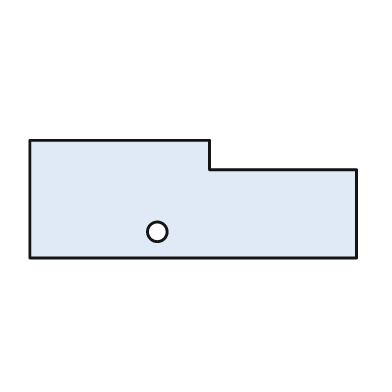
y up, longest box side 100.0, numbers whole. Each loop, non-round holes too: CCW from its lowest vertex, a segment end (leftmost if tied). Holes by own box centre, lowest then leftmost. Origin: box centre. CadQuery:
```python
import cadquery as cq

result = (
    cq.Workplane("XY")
    .moveTo(-50.0, -18.0)
    .lineTo(50.0, -18.0)
    .lineTo(50.0, 9.0)
    .lineTo(5.0, 9.0)
    .lineTo(5.0, 18.0)
    .lineTo(-50.0, 18.0)
    .close()
    .moveTo(-11.0, -10.0)
    .circle(3.0)
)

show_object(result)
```